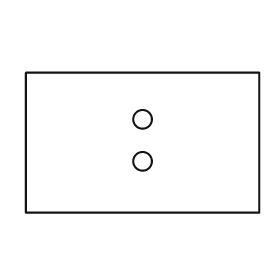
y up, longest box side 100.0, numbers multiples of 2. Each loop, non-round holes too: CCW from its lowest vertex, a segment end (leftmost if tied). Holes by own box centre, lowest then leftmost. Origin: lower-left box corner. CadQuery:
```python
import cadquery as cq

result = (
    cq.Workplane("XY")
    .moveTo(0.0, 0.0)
    .lineTo(100.0, 0.0)
    .lineTo(100.0, 60.0)
    .lineTo(0.0, 60.0)
    .close()
    .moveTo(50.0, 22.0)
    .circle(4.0)
    .moveTo(50.0, 40.0)
    .circle(4.0)
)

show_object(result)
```